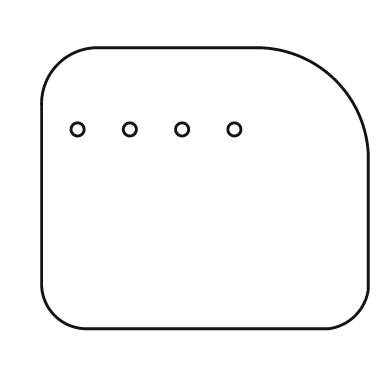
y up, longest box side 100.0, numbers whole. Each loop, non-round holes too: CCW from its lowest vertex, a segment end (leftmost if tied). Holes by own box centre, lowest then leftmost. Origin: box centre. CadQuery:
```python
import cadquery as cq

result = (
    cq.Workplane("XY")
    .moveTo(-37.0, -43.0)
    .lineTo(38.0, -43.0)
    .threePointArc((46.0, -39.0), (50.0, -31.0))
    .lineTo(50.0, 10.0)
    .threePointArc((40.0, 33.0), (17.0, 43.0))
    .lineTo(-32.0, 43.0)
    .threePointArc((-45.0, 38.0), (-50.0, 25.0))
    .lineTo(-50.0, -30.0)
    .threePointArc((-46.0, -39.0), (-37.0, -43.0))
    .close()
    .moveTo(-39.0, 18.0)
    .circle(2.0)
    .moveTo(-23.0, 18.0)
    .circle(2.0)
    .moveTo(-7.0, 18.0)
    .circle(2.0)
    .moveTo(9.0, 18.0)
    .circle(2.0)
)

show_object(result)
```